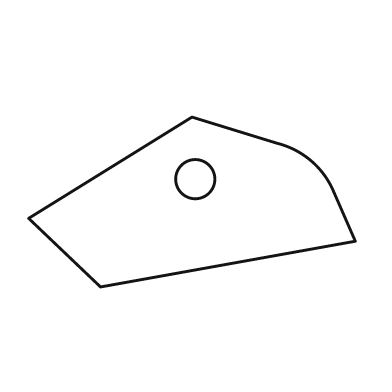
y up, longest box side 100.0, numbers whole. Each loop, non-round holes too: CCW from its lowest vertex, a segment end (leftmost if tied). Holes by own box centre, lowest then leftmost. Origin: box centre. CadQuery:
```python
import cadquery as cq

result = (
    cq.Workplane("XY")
    .moveTo(-28.0, -26.0)
    .lineTo(50.0, -12.0)
    .lineTo(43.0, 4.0)
    .threePointArc((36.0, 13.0), (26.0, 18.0))
    .lineTo(0.0, 26.0)
    .lineTo(-50.0, -5.0)
    .close()
    .moveTo(1.0, 7.0)
    .circle(6.0)
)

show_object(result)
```